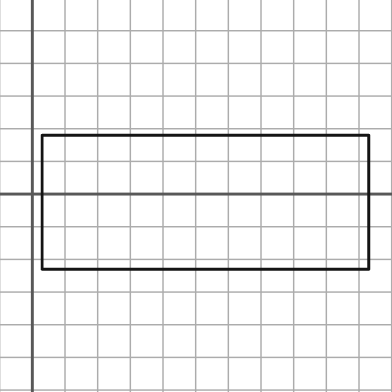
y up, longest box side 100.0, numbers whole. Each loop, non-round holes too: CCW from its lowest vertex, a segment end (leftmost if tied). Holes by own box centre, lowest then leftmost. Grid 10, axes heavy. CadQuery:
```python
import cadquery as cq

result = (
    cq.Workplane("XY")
    .moveTo(3.0, -23.0)
    .lineTo(103.0, -23.0)
    .lineTo(103.0, 18.0)
    .lineTo(3.0, 18.0)
    .close()
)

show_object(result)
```